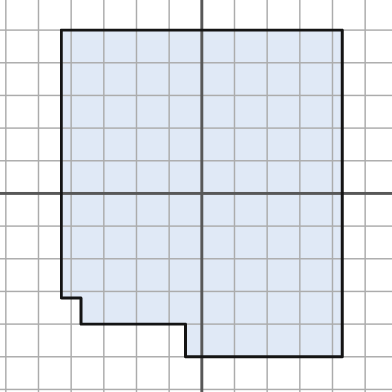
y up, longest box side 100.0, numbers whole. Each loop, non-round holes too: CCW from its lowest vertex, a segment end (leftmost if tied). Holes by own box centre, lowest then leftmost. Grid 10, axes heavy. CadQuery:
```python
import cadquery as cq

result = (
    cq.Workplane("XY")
    .moveTo(-5.0, -50.0)
    .lineTo(43.0, -50.0)
    .lineTo(43.0, 50.0)
    .lineTo(-43.0, 50.0)
    .lineTo(-43.0, -32.0)
    .lineTo(-37.0, -32.0)
    .lineTo(-37.0, -40.0)
    .lineTo(-5.0, -40.0)
    .close()
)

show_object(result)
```